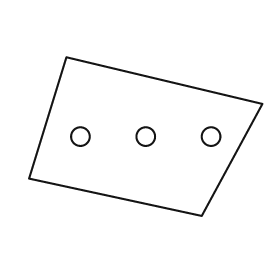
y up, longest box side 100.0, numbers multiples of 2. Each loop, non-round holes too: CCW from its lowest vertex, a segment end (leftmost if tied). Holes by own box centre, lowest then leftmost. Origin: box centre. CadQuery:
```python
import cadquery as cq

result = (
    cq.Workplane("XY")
    .moveTo(24.0, -34.0)
    .lineTo(50.0, 14.0)
    .lineTo(-34.0, 34.0)
    .lineTo(-50.0, -18.0)
    .close()
    .moveTo(-28.0, 0.0)
    .circle(4.0)
    .moveTo(0.0, 0.0)
    .circle(4.0)
    .moveTo(28.0, 0.0)
    .circle(4.0)
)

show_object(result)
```